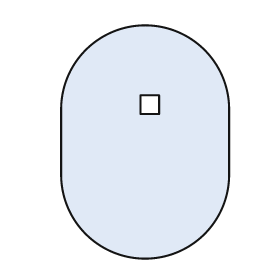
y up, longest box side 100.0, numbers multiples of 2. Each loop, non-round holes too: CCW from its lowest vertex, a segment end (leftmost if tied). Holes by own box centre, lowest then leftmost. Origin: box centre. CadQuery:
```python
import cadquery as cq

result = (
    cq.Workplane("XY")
    .moveTo(-36.0, -14.0)
    .threePointArc((0.0, -50.0), (36.0, -14.0))
    .lineTo(36.0, 14.0)
    .threePointArc((0.0, 50.0), (-36.0, 14.0))
    .close()
    .moveTo(-2.0, 12.0)
    .lineTo(6.0, 12.0)
    .lineTo(6.0, 20.0)
    .lineTo(-2.0, 20.0)
    .close()
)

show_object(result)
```